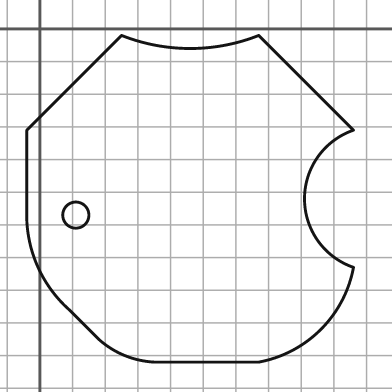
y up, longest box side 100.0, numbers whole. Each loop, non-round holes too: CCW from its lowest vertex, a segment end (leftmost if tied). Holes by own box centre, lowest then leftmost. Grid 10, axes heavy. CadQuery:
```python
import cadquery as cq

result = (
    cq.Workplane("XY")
    .moveTo(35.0, -102.0)
    .lineTo(67.0, -102.0)
    .threePointArc((86.0, -92.0), (96.0, -73.0))
    .threePointArc((81.0, -52.0), (96.0, -31.0))
    .lineTo(67.0, -2.0)
    .threePointArc((46.0, -6.0), (25.0, -2.0))
    .lineTo(-4.0, -31.0)
    .lineTo(-4.0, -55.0)
    .threePointArc((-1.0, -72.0), (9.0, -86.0))
    .lineTo(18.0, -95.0)
    .threePointArc((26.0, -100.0), (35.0, -102.0))
    .close()
    .moveTo(11.0, -57.0)
    .circle(4.0)
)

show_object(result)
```